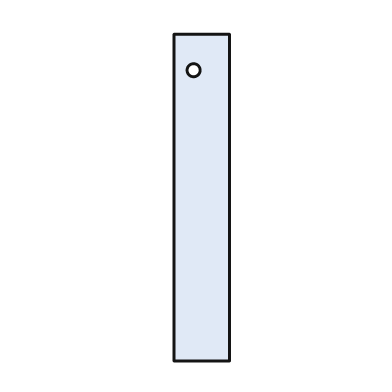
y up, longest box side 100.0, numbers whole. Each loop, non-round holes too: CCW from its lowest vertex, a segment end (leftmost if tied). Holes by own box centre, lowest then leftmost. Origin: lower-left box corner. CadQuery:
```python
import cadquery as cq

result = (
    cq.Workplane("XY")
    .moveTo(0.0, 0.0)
    .lineTo(17.0, 0.0)
    .lineTo(17.0, 100.0)
    .lineTo(0.0, 100.0)
    .close()
    .moveTo(6.0, 89.0)
    .circle(2.0)
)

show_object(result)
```